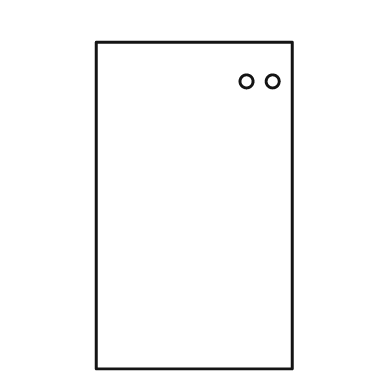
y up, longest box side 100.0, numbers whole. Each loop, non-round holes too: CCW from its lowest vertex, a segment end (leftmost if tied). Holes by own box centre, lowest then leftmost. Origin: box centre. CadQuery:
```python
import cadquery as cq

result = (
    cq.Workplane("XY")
    .moveTo(-30.0, -50.0)
    .lineTo(30.0, -50.0)
    .lineTo(30.0, 50.0)
    .lineTo(-30.0, 50.0)
    .close()
    .moveTo(16.0, 38.0)
    .circle(2.0)
    .moveTo(24.0, 38.0)
    .circle(2.0)
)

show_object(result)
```